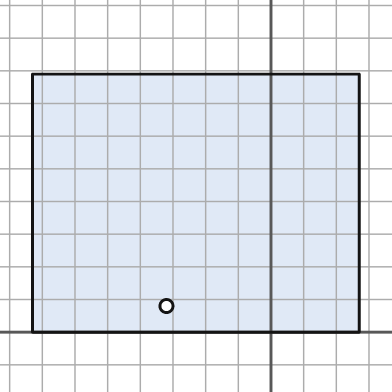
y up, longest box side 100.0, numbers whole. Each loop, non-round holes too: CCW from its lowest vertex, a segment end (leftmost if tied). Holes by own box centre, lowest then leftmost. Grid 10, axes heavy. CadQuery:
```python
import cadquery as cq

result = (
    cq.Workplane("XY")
    .moveTo(-73.0, 0.0)
    .lineTo(27.0, 0.0)
    .lineTo(27.0, 79.0)
    .lineTo(-73.0, 79.0)
    .close()
    .moveTo(-32.0, 8.0)
    .circle(2.0)
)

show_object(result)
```